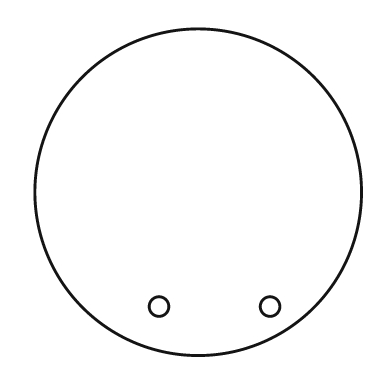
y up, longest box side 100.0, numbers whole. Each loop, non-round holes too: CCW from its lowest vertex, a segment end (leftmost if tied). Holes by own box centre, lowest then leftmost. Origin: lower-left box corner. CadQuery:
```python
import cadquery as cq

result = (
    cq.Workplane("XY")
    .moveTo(50.0, 50.0)
    .circle(50.0)
    .moveTo(38.0, 15.0)
    .circle(3.0)
    .moveTo(72.0, 15.0)
    .circle(3.0)
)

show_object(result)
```